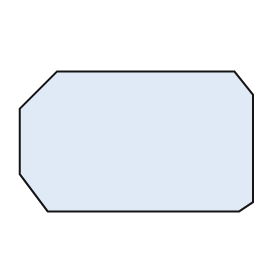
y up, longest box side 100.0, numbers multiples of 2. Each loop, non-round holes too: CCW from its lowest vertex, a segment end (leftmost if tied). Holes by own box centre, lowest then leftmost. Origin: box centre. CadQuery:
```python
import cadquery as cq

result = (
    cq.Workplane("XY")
    .moveTo(-38.0, -30.0)
    .lineTo(44.0, -30.0)
    .lineTo(50.0, -26.0)
    .lineTo(50.0, 20.0)
    .lineTo(42.0, 30.0)
    .lineTo(-34.0, 30.0)
    .lineTo(-50.0, 14.0)
    .lineTo(-50.0, -14.0)
    .close()
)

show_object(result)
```